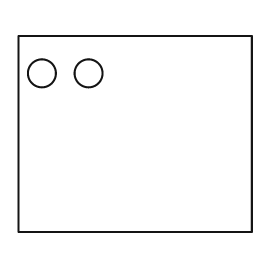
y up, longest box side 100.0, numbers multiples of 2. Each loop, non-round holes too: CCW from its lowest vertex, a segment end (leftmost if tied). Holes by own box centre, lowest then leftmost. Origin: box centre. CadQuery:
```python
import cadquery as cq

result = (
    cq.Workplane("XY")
    .moveTo(-50.0, -42.0)
    .lineTo(50.0, -42.0)
    .lineTo(50.0, 42.0)
    .lineTo(-50.0, 42.0)
    .close()
    .moveTo(-40.0, 26.0)
    .circle(6.0)
    .moveTo(-20.0, 26.0)
    .circle(6.0)
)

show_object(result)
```